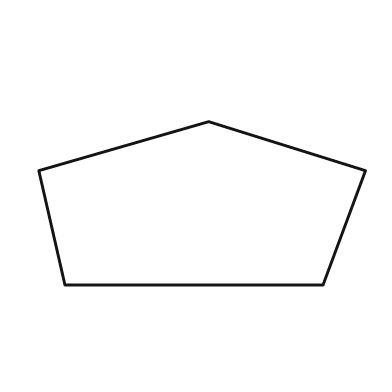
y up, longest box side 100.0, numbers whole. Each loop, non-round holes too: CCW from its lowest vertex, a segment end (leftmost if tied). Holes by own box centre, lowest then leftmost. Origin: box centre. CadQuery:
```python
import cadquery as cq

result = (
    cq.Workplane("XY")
    .moveTo(-42.0, -25.0)
    .lineTo(37.0, -25.0)
    .lineTo(50.0, 10.0)
    .lineTo(2.0, 25.0)
    .lineTo(-50.0, 10.0)
    .close()
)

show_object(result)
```